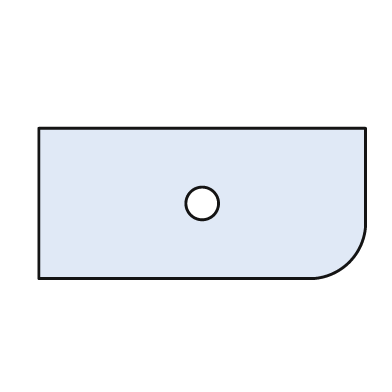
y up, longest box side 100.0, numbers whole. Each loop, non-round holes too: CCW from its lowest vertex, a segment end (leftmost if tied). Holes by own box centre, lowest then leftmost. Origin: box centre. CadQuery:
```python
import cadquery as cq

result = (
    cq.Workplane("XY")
    .moveTo(-50.0, -23.0)
    .lineTo(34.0, -23.0)
    .threePointArc((45.0, -18.0), (50.0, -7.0))
    .lineTo(50.0, 23.0)
    .lineTo(-50.0, 23.0)
    .close()
    .moveTo(0.0, 0.0)
    .circle(5.0)
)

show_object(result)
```